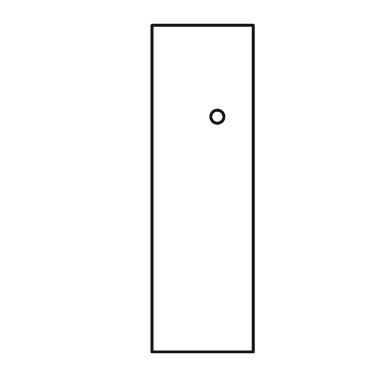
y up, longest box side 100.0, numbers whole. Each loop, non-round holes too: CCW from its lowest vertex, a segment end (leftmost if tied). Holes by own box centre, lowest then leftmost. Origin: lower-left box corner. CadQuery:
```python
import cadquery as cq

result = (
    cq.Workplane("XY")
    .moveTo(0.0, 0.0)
    .lineTo(31.0, 0.0)
    .lineTo(31.0, 100.0)
    .lineTo(0.0, 100.0)
    .close()
    .moveTo(20.0, 72.0)
    .circle(2.0)
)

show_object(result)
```